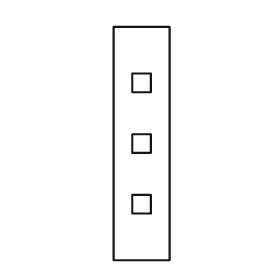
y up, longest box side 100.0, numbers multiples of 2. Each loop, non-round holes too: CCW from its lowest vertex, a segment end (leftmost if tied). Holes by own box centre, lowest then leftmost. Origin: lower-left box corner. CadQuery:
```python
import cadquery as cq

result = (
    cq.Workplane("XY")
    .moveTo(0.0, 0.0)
    .lineTo(24.0, 0.0)
    .lineTo(24.0, 100.0)
    .lineTo(0.0, 100.0)
    .close()
    .moveTo(8.0, 20.0)
    .lineTo(16.0, 20.0)
    .lineTo(16.0, 28.0)
    .lineTo(8.0, 28.0)
    .close()
    .moveTo(8.0, 46.0)
    .lineTo(16.0, 46.0)
    .lineTo(16.0, 54.0)
    .lineTo(8.0, 54.0)
    .close()
    .moveTo(8.0, 72.0)
    .lineTo(16.0, 72.0)
    .lineTo(16.0, 80.0)
    .lineTo(8.0, 80.0)
    .close()
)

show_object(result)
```